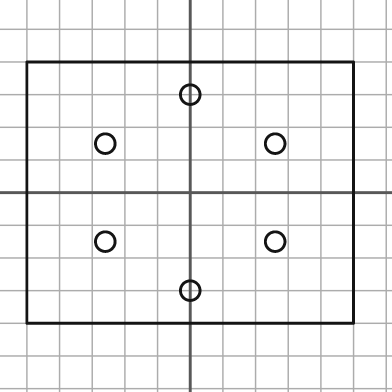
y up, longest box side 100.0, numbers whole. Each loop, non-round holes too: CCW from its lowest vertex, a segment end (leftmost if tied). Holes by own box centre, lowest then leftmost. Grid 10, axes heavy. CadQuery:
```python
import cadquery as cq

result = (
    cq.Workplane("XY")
    .moveTo(-50.0, -40.0)
    .lineTo(50.0, -40.0)
    .lineTo(50.0, 40.0)
    .lineTo(-50.0, 40.0)
    .close()
    .moveTo(0.0, -30.0)
    .circle(3.0)
    .moveTo(-26.0, -15.0)
    .circle(3.0)
    .moveTo(26.0, -15.0)
    .circle(3.0)
    .moveTo(-26.0, 15.0)
    .circle(3.0)
    .moveTo(26.0, 15.0)
    .circle(3.0)
    .moveTo(0.0, 30.0)
    .circle(3.0)
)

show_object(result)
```